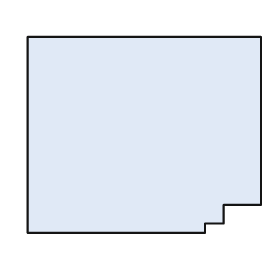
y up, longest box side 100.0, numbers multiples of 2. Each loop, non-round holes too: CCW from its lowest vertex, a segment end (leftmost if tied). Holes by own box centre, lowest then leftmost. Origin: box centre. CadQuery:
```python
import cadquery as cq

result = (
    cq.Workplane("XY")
    .moveTo(-50.0, -42.0)
    .lineTo(26.0, -42.0)
    .lineTo(26.0, -38.0)
    .lineTo(34.0, -38.0)
    .lineTo(34.0, -30.0)
    .lineTo(50.0, -30.0)
    .lineTo(50.0, 42.0)
    .lineTo(-50.0, 42.0)
    .close()
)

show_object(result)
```